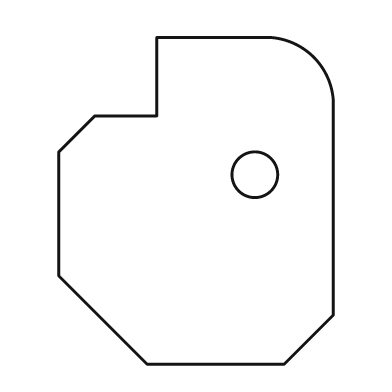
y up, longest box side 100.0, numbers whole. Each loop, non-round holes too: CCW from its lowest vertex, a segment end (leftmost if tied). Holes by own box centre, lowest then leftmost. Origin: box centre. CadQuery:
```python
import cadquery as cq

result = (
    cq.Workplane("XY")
    .moveTo(-15.0, -50.0)
    .lineTo(27.0, -50.0)
    .lineTo(42.0, -35.0)
    .lineTo(42.0, 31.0)
    .threePointArc((36.0, 44.0), (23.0, 50.0))
    .lineTo(-12.0, 50.0)
    .lineTo(-12.0, 26.0)
    .lineTo(-31.0, 26.0)
    .lineTo(-42.0, 15.0)
    .lineTo(-42.0, -23.0)
    .close()
    .moveTo(18.0, 8.0)
    .circle(7.0)
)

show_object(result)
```